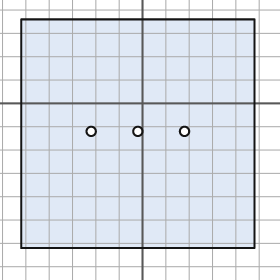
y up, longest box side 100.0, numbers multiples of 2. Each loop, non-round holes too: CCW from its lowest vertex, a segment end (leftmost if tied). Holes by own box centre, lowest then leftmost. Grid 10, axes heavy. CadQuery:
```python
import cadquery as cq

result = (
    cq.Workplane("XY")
    .moveTo(-52.0, -62.0)
    .lineTo(48.0, -62.0)
    .lineTo(48.0, 36.0)
    .lineTo(-52.0, 36.0)
    .close()
    .moveTo(-22.0, -12.0)
    .circle(2.0)
    .moveTo(-2.0, -12.0)
    .circle(2.0)
    .moveTo(18.0, -12.0)
    .circle(2.0)
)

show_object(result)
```